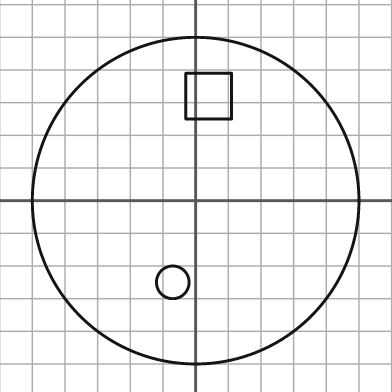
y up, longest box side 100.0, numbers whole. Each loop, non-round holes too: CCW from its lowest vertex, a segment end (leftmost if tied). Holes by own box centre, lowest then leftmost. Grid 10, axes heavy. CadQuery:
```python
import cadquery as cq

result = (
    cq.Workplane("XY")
    .moveTo(0.0, 0.0)
    .circle(50.0)
    .moveTo(-7.0, -25.0)
    .circle(5.0)
    .moveTo(-3.0, 25.0)
    .lineTo(11.0, 25.0)
    .lineTo(11.0, 39.0)
    .lineTo(-3.0, 39.0)
    .close()
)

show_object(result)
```